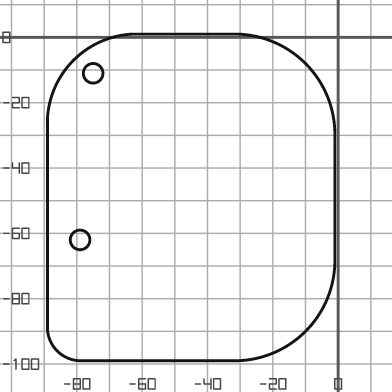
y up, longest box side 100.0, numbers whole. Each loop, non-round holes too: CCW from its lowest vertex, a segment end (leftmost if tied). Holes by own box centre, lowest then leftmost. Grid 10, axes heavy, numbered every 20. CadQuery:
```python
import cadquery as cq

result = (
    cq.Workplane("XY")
    .moveTo(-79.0, -99.0)
    .lineTo(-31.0, -99.0)
    .threePointArc((-10.0, -90.0), (-1.0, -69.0))
    .lineTo(-1.0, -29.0)
    .threePointArc((-10.0, -8.0), (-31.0, 1.0))
    .lineTo(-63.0, 1.0)
    .threePointArc((-81.0, -7.0), (-89.0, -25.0))
    .lineTo(-89.0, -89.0)
    .threePointArc((-86.0, -96.0), (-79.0, -99.0))
    .close()
    .moveTo(-79.0, -62.0)
    .circle(3.0)
    .moveTo(-75.0, -11.0)
    .circle(3.0)
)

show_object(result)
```